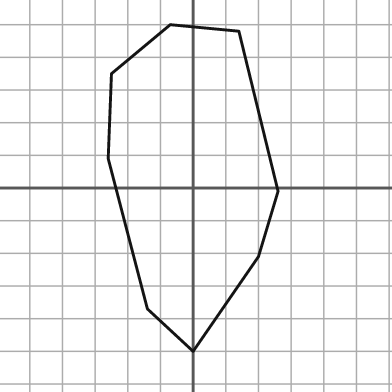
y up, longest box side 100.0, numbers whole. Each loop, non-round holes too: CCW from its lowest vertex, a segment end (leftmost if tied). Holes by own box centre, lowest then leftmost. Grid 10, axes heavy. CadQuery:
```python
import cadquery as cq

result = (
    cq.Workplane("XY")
    .moveTo(0.0, -50.0)
    .lineTo(20.0, -21.0)
    .lineTo(26.0, -1.0)
    .lineTo(14.0, 48.0)
    .lineTo(-7.0, 50.0)
    .lineTo(-25.0, 35.0)
    .lineTo(-26.0, 9.0)
    .lineTo(-14.0, -37.0)
    .close()
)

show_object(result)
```